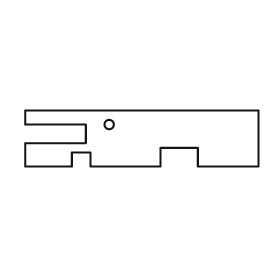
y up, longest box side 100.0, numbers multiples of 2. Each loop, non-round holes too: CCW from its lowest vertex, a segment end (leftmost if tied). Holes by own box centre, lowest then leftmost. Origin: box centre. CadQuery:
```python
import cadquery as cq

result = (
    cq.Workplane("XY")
    .moveTo(-50.0, -12.0)
    .lineTo(-30.0, -12.0)
    .lineTo(-30.0, -6.0)
    .lineTo(-22.0, -6.0)
    .lineTo(-22.0, -12.0)
    .lineTo(8.0, -12.0)
    .lineTo(8.0, -4.0)
    .lineTo(24.0, -4.0)
    .lineTo(24.0, -12.0)
    .lineTo(50.0, -12.0)
    .lineTo(50.0, 12.0)
    .lineTo(-50.0, 12.0)
    .lineTo(-50.0, 6.0)
    .lineTo(-24.0, 6.0)
    .lineTo(-24.0, -2.0)
    .lineTo(-50.0, -2.0)
    .close()
    .moveTo(-14.0, 6.0)
    .circle(2.0)
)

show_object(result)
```